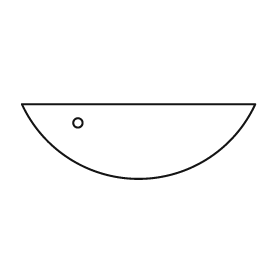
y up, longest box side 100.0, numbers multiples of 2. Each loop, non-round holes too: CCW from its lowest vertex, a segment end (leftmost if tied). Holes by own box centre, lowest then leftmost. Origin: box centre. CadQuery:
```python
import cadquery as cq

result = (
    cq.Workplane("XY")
    .moveTo(-50.0, 16.0)
    .threePointArc((0.0, -16.0), (50.0, 16.0))
    .close()
    .moveTo(-26.0, 8.0)
    .circle(2.0)
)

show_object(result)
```